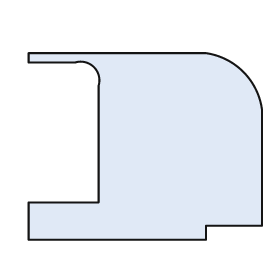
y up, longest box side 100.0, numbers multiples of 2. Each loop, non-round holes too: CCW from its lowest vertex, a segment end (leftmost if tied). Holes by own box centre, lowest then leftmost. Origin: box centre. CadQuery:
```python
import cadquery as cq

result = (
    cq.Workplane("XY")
    .moveTo(-50.0, -40.0)
    .lineTo(26.0, -40.0)
    .lineTo(26.0, -34.0)
    .lineTo(50.0, -34.0)
    .lineTo(50.0, 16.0)
    .threePointArc((42.0, 32.0), (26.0, 40.0))
    .lineTo(-50.0, 40.0)
    .lineTo(-50.0, 36.0)
    .lineTo(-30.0, 36.0)
    .threePointArc((-22.0, 34.0), (-20.0, 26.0))
    .lineTo(-20.0, -24.0)
    .lineTo(-50.0, -24.0)
    .close()
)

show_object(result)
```